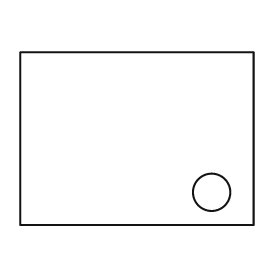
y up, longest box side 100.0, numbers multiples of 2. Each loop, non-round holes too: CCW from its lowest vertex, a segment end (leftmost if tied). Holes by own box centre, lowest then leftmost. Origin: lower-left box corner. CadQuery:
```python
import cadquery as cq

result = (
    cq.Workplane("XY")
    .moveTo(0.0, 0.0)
    .lineTo(100.0, 0.0)
    .lineTo(100.0, 74.0)
    .lineTo(0.0, 74.0)
    .close()
    .moveTo(82.0, 14.0)
    .circle(8.0)
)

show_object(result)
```